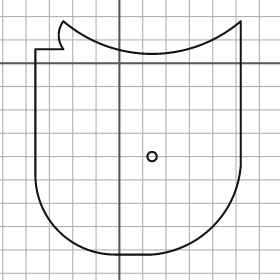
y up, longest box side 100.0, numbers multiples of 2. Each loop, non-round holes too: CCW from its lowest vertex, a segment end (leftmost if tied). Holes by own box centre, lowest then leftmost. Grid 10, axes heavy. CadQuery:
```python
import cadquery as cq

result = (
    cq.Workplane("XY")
    .moveTo(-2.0, -82.0)
    .lineTo(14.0, -82.0)
    .threePointArc((40.0, -70.0), (52.0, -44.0))
    .lineTo(52.0, 18.0)
    .threePointArc((14.0, 4.0), (-24.0, 18.0))
    .threePointArc((-26.0, 12.0), (-24.0, 6.0))
    .lineTo(-36.0, 6.0)
    .lineTo(-36.0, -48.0)
    .threePointArc((-26.0, -72.0), (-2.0, -82.0))
    .close()
    .moveTo(14.0, -40.0)
    .circle(2.0)
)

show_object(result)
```